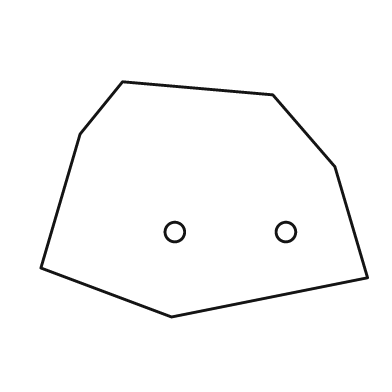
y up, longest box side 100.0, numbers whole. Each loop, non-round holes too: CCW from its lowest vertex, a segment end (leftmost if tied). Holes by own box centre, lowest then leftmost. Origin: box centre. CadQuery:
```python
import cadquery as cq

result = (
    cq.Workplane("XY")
    .moveTo(-10.0, -36.0)
    .lineTo(50.0, -24.0)
    .lineTo(40.0, 10.0)
    .lineTo(21.0, 32.0)
    .lineTo(-25.0, 36.0)
    .lineTo(-38.0, 20.0)
    .lineTo(-50.0, -21.0)
    .close()
    .moveTo(-9.0, -10.0)
    .circle(3.0)
    .moveTo(25.0, -10.0)
    .circle(3.0)
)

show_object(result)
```